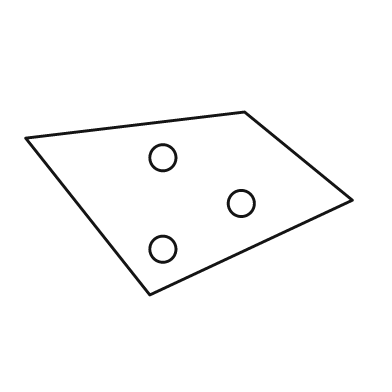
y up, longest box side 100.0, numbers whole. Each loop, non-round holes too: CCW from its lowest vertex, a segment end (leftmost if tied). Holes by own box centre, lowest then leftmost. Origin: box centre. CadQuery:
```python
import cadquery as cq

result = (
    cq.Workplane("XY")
    .moveTo(-12.0, -28.0)
    .lineTo(50.0, 1.0)
    .lineTo(17.0, 28.0)
    .lineTo(-50.0, 20.0)
    .close()
    .moveTo(-8.0, -14.0)
    .circle(4.0)
    .moveTo(16.0, 0.0)
    .circle(4.0)
    .moveTo(-8.0, 14.0)
    .circle(4.0)
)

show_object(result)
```